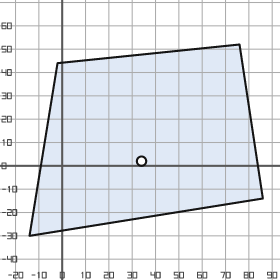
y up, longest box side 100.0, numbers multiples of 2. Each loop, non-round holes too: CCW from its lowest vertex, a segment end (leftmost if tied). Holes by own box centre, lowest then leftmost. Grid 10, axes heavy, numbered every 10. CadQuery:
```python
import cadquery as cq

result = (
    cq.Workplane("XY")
    .moveTo(-14.0, -30.0)
    .lineTo(86.0, -14.0)
    .lineTo(76.0, 52.0)
    .lineTo(-2.0, 44.0)
    .close()
    .moveTo(34.0, 2.0)
    .circle(2.0)
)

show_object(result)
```